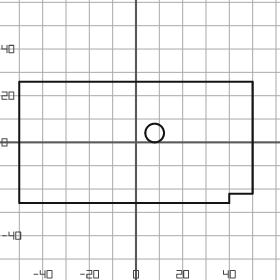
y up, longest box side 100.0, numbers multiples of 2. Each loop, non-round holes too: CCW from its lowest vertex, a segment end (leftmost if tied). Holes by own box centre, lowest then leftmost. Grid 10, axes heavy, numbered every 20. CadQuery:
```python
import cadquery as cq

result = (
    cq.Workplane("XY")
    .moveTo(-50.0, -26.0)
    .lineTo(40.0, -26.0)
    .lineTo(40.0, -22.0)
    .lineTo(50.0, -22.0)
    .lineTo(50.0, 26.0)
    .lineTo(-50.0, 26.0)
    .close()
    .moveTo(8.0, 4.0)
    .circle(4.0)
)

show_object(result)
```